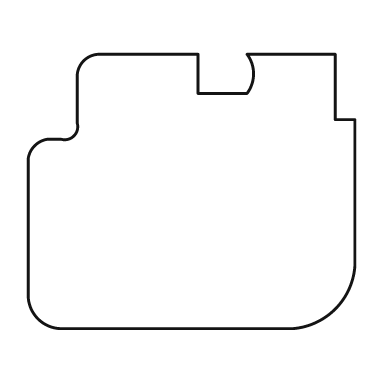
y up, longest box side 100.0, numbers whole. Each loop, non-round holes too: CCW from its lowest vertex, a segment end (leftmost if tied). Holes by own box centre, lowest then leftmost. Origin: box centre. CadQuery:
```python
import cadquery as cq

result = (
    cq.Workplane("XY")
    .moveTo(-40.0, -42.0)
    .lineTo(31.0, -42.0)
    .threePointArc((44.0, -36.0), (50.0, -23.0))
    .lineTo(50.0, 22.0)
    .lineTo(44.0, 22.0)
    .lineTo(44.0, 42.0)
    .lineTo(17.0, 42.0)
    .threePointArc((19.0, 36.0), (17.0, 30.0))
    .lineTo(2.0, 30.0)
    .lineTo(2.0, 42.0)
    .lineTo(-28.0, 42.0)
    .threePointArc((-33.0, 40.0), (-35.0, 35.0))
    .lineTo(-35.0, 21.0)
    .threePointArc((-36.0, 17.0), (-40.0, 16.0))
    .lineTo(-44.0, 16.0)
    .threePointArc((-48.0, 14.0), (-50.0, 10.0))
    .lineTo(-50.0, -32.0)
    .threePointArc((-47.0, -39.0), (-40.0, -42.0))
    .close()
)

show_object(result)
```